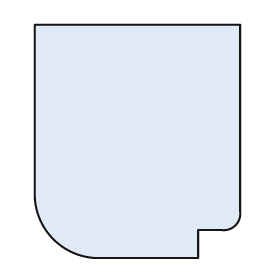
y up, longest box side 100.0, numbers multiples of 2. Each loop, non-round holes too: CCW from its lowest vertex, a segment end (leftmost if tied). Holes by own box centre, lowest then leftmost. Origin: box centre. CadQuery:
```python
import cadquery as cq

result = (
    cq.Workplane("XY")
    .moveTo(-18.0, -50.0)
    .lineTo(26.0, -50.0)
    .lineTo(26.0, -38.0)
    .lineTo(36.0, -38.0)
    .threePointArc((42.0, -36.0), (44.0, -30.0))
    .lineTo(44.0, 50.0)
    .lineTo(-44.0, 50.0)
    .lineTo(-44.0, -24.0)
    .threePointArc((-36.0, -42.0), (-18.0, -50.0))
    .close()
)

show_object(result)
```